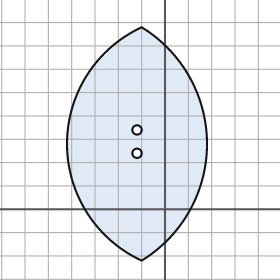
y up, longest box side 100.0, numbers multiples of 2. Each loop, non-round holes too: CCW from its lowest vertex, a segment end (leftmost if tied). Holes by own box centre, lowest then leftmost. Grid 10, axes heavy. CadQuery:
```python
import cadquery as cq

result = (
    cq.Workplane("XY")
    .moveTo(-10.0, -22.0)
    .threePointArc((18.0, 28.0), (-10.0, 78.0))
    .threePointArc((-42.0, 28.0), (-10.0, -22.0))
    .close()
    .moveTo(-12.0, 24.0)
    .circle(2.0)
    .moveTo(-12.0, 34.0)
    .circle(2.0)
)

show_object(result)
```